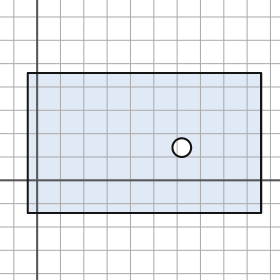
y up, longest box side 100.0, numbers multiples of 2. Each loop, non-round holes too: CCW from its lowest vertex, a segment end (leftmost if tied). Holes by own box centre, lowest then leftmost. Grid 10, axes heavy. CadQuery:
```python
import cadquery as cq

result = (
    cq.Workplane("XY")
    .moveTo(-4.0, -14.0)
    .lineTo(96.0, -14.0)
    .lineTo(96.0, 46.0)
    .lineTo(-4.0, 46.0)
    .close()
    .moveTo(62.0, 14.0)
    .circle(4.0)
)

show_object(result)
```